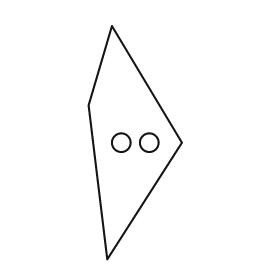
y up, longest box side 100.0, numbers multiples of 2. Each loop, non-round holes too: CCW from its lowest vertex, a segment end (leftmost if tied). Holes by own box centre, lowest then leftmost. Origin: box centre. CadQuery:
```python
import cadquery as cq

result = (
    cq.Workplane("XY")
    .moveTo(-12.0, -50.0)
    .lineTo(20.0, 0.0)
    .lineTo(-10.0, 50.0)
    .lineTo(-20.0, 16.0)
    .close()
    .moveTo(-6.0, 0.0)
    .circle(4.0)
    .moveTo(6.0, 0.0)
    .circle(4.0)
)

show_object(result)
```